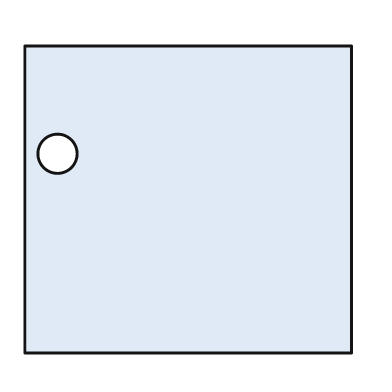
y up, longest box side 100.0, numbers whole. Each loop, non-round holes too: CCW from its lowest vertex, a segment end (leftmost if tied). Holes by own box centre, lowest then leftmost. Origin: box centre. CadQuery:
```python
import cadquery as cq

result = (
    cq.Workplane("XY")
    .moveTo(-50.0, -47.0)
    .lineTo(50.0, -47.0)
    .lineTo(50.0, 47.0)
    .lineTo(-50.0, 47.0)
    .close()
    .moveTo(-40.0, 14.0)
    .circle(6.0)
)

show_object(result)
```